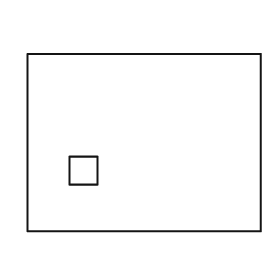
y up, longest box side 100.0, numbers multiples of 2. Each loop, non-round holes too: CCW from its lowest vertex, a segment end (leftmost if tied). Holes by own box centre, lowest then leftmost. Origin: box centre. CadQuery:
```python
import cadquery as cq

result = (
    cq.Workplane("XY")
    .moveTo(-50.0, -38.0)
    .lineTo(50.0, -38.0)
    .lineTo(50.0, 38.0)
    .lineTo(-50.0, 38.0)
    .close()
    .moveTo(-32.0, -18.0)
    .lineTo(-20.0, -18.0)
    .lineTo(-20.0, -6.0)
    .lineTo(-32.0, -6.0)
    .close()
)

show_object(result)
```